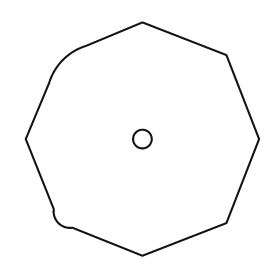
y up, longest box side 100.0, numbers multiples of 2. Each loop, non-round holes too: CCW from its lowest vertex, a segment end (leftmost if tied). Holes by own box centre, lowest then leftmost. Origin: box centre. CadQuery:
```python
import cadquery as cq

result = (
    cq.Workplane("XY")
    .moveTo(0.0, -50.0)
    .lineTo(36.0, -36.0)
    .lineTo(50.0, 0.0)
    .lineTo(36.0, 36.0)
    .lineTo(0.0, 50.0)
    .lineTo(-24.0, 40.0)
    .threePointArc((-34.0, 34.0), (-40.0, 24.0))
    .lineTo(-50.0, 0.0)
    .lineTo(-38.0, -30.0)
    .threePointArc((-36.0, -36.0), (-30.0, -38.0))
    .close()
    .moveTo(0.0, 0.0)
    .circle(4.0)
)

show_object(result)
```